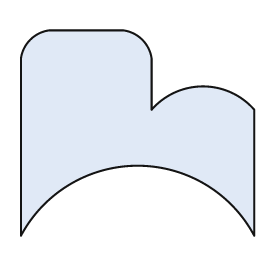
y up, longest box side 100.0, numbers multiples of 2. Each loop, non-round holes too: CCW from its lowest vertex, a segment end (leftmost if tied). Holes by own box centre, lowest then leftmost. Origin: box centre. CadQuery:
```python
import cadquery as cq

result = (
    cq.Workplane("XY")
    .moveTo(-50.0, -44.0)
    .threePointArc((0.0, -14.0), (50.0, -44.0))
    .lineTo(50.0, 10.0)
    .threePointArc((28.0, 20.0), (6.0, 10.0))
    .lineTo(6.0, 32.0)
    .threePointArc((2.0, 40.0), (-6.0, 44.0))
    .lineTo(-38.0, 44.0)
    .threePointArc((-46.0, 40.0), (-50.0, 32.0))
    .close()
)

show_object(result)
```